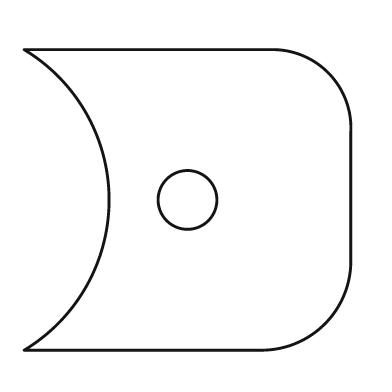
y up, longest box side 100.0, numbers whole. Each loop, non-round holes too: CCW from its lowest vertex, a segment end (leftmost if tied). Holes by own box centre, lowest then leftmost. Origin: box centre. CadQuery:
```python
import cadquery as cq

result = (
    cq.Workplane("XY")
    .moveTo(-50.0, -46.0)
    .lineTo(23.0, -46.0)
    .threePointArc((42.0, -38.0), (50.0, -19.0))
    .lineTo(50.0, 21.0)
    .threePointArc((43.0, 39.0), (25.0, 46.0))
    .lineTo(-50.0, 46.0)
    .threePointArc((-24.0, 0.0), (-50.0, -46.0))
    .close()
    .moveTo(0.0, 0.0)
    .circle(9.0)
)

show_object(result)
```